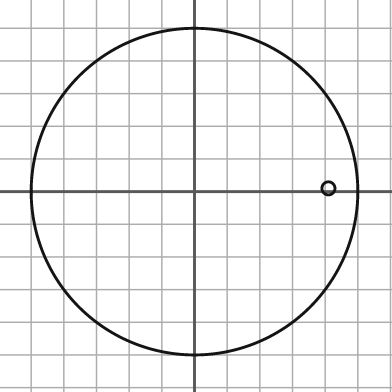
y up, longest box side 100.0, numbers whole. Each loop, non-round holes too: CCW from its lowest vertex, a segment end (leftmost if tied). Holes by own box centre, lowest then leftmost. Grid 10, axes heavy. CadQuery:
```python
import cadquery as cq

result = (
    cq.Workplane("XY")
    .moveTo(0.0, 0.0)
    .circle(50.0)
    .moveTo(41.0, 1.0)
    .circle(2.0)
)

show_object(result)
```